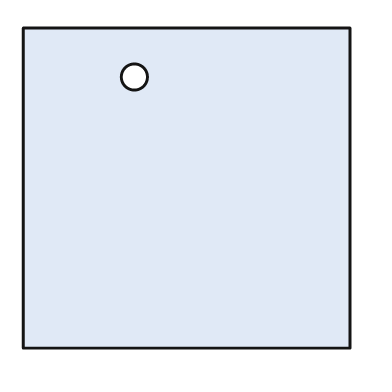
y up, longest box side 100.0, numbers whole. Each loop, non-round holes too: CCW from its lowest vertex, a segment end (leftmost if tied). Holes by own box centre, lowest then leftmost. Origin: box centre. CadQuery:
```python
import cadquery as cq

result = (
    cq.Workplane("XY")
    .moveTo(-50.0, -49.0)
    .lineTo(50.0, -49.0)
    .lineTo(50.0, 49.0)
    .lineTo(-50.0, 49.0)
    .close()
    .moveTo(-16.0, 34.0)
    .circle(4.0)
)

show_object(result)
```